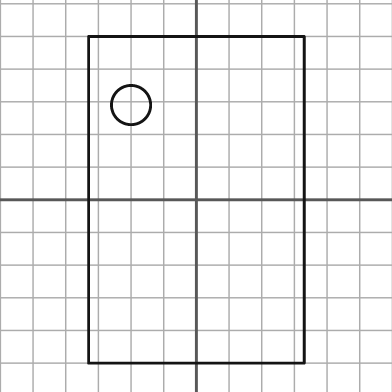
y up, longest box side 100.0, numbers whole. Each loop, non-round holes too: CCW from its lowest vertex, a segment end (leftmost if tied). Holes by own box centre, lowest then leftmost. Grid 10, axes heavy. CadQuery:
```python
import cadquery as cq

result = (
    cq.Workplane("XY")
    .moveTo(-33.0, -50.0)
    .lineTo(33.0, -50.0)
    .lineTo(33.0, 50.0)
    .lineTo(-33.0, 50.0)
    .close()
    .moveTo(-20.0, 29.0)
    .circle(6.0)
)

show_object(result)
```